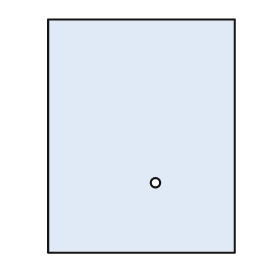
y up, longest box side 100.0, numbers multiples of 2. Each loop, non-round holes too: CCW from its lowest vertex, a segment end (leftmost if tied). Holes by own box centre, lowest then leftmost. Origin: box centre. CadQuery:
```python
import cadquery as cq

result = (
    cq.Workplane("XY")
    .moveTo(-40.0, -50.0)
    .lineTo(40.0, -50.0)
    .lineTo(40.0, 50.0)
    .lineTo(-40.0, 50.0)
    .close()
    .moveTo(6.0, -20.0)
    .circle(2.0)
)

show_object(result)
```